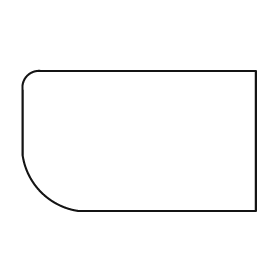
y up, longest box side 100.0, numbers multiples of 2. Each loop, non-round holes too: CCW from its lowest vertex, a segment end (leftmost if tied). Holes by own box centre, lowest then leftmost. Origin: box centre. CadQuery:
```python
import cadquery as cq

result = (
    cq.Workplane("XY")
    .moveTo(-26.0, -30.0)
    .lineTo(50.0, -30.0)
    .lineTo(50.0, 30.0)
    .lineTo(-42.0, 30.0)
    .threePointArc((-48.0, 28.0), (-50.0, 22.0))
    .lineTo(-50.0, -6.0)
    .threePointArc((-42.0, -22.0), (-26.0, -30.0))
    .close()
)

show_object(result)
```